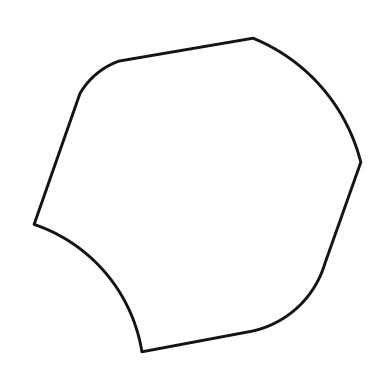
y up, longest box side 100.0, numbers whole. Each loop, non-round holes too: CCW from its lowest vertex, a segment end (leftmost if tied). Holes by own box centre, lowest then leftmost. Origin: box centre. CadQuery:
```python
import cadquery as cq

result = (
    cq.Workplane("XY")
    .moveTo(-17.0, -48.0)
    .lineTo(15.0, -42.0)
    .threePointArc((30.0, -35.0), (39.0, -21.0))
    .lineTo(50.0, 10.0)
    .threePointArc((38.0, 33.0), (17.0, 48.0))
    .lineTo(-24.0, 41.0)
    .threePointArc((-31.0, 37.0), (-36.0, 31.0))
    .lineTo(-50.0, -9.0)
    .threePointArc((-28.0, -24.0), (-17.0, -48.0))
    .close()
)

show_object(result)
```